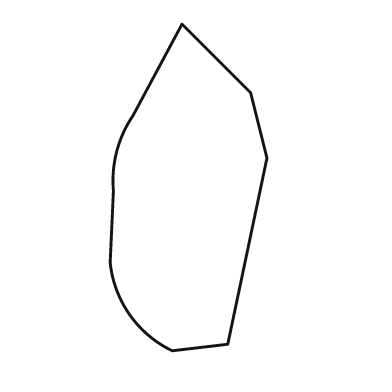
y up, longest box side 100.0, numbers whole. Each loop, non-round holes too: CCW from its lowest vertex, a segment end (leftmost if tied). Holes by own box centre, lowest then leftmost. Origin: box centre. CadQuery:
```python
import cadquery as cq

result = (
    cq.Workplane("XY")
    .moveTo(-5.0, -50.0)
    .lineTo(12.0, -48.0)
    .lineTo(24.0, 9.0)
    .lineTo(19.0, 29.0)
    .lineTo(-2.0, 50.0)
    .lineTo(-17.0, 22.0)
    .threePointArc((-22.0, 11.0), (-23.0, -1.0))
    .lineTo(-24.0, -23.0)
    .threePointArc((-18.0, -39.0), (-5.0, -50.0))
    .close()
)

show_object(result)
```